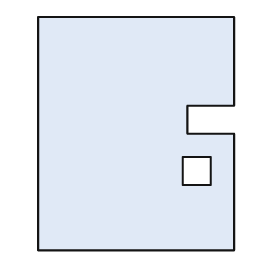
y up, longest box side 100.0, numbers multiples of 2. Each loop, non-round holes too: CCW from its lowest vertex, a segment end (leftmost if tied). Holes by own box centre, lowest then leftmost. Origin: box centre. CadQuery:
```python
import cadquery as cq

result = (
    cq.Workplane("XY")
    .moveTo(-42.0, -50.0)
    .lineTo(42.0, -50.0)
    .lineTo(42.0, 0.0)
    .lineTo(22.0, 0.0)
    .lineTo(22.0, 12.0)
    .lineTo(42.0, 12.0)
    .lineTo(42.0, 50.0)
    .lineTo(-42.0, 50.0)
    .close()
    .moveTo(20.0, -22.0)
    .lineTo(32.0, -22.0)
    .lineTo(32.0, -10.0)
    .lineTo(20.0, -10.0)
    .close()
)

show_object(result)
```